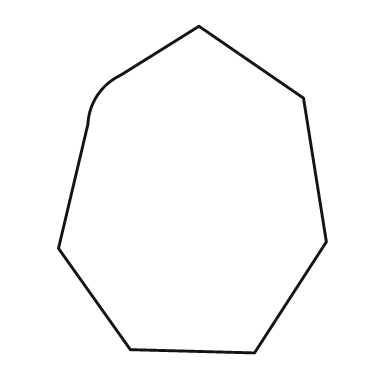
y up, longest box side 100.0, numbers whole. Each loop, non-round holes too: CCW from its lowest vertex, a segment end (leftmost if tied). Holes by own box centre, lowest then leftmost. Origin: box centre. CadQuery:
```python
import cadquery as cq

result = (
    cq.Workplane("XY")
    .moveTo(19.0, -50.0)
    .lineTo(41.0, -16.0)
    .lineTo(34.0, 28.0)
    .lineTo(2.0, 50.0)
    .lineTo(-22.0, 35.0)
    .threePointArc((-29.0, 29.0), (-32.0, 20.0))
    .lineTo(-41.0, -18.0)
    .lineTo(-19.0, -49.0)
    .close()
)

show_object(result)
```